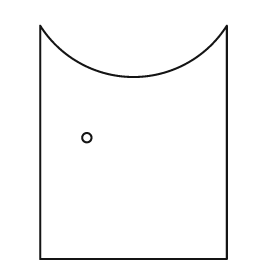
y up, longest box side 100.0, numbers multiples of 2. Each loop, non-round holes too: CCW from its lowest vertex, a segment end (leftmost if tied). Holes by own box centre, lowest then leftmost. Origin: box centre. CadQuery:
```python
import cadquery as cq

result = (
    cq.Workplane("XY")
    .moveTo(-40.0, -50.0)
    .lineTo(40.0, -50.0)
    .lineTo(40.0, 50.0)
    .threePointArc((0.0, 28.0), (-40.0, 50.0))
    .close()
    .moveTo(-20.0, 2.0)
    .circle(2.0)
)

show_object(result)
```